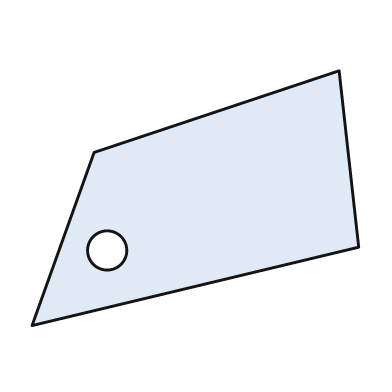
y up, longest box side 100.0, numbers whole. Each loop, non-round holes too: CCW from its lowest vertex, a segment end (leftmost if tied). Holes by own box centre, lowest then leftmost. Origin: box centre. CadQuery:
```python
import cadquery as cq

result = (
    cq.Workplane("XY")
    .moveTo(-50.0, -39.0)
    .lineTo(50.0, -15.0)
    .lineTo(44.0, 39.0)
    .lineTo(-31.0, 14.0)
    .close()
    .moveTo(-27.0, -16.0)
    .circle(6.0)
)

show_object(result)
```